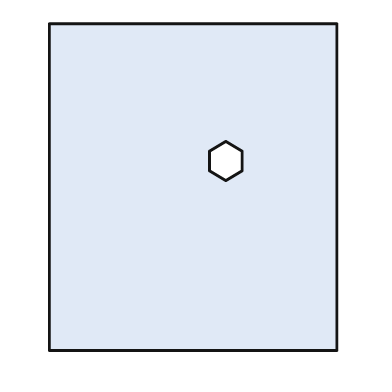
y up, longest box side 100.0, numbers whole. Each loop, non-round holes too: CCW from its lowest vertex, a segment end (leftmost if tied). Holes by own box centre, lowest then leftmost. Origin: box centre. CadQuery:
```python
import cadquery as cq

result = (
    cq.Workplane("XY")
    .moveTo(-44.0, -50.0)
    .lineTo(44.0, -50.0)
    .lineTo(44.0, 50.0)
    .lineTo(-44.0, 50.0)
    .close()
    .moveTo(10.0, 2.0)
    .lineTo(15.0, 5.0)
    .lineTo(15.0, 11.0)
    .lineTo(10.0, 14.0)
    .lineTo(5.0, 11.0)
    .lineTo(5.0, 5.0)
    .close()
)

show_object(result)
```